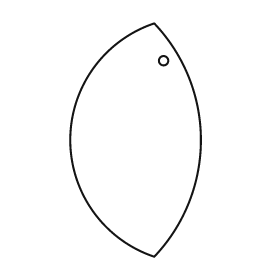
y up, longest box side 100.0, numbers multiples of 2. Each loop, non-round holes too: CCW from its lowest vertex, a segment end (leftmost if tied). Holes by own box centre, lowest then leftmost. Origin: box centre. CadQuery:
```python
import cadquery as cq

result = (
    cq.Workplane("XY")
    .moveTo(8.0, -50.0)
    .threePointArc((28.0, 0.0), (8.0, 50.0))
    .threePointArc((-28.0, 0.0), (8.0, -50.0))
    .close()
    .moveTo(12.0, 34.0)
    .circle(2.0)
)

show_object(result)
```